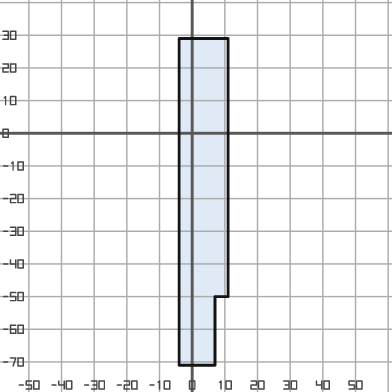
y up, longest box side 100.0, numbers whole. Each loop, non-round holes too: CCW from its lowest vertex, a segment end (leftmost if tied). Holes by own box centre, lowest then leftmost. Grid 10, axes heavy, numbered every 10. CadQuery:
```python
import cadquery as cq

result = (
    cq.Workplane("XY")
    .moveTo(-4.0, -71.0)
    .lineTo(7.0, -71.0)
    .lineTo(7.0, -50.0)
    .lineTo(11.0, -50.0)
    .lineTo(11.0, 29.0)
    .lineTo(-4.0, 29.0)
    .close()
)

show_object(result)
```